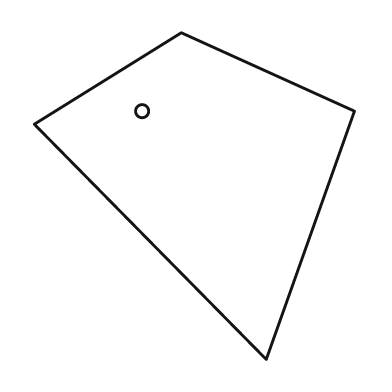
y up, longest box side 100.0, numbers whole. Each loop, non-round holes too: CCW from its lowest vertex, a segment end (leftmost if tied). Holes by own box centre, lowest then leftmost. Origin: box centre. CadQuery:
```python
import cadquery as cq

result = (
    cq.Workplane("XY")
    .moveTo(22.0, -50.0)
    .lineTo(49.0, 26.0)
    .lineTo(-4.0, 50.0)
    .lineTo(-49.0, 22.0)
    .close()
    .moveTo(-16.0, 26.0)
    .circle(2.0)
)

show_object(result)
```